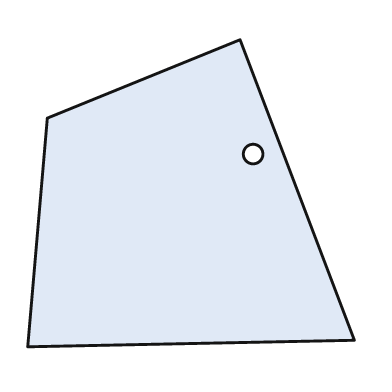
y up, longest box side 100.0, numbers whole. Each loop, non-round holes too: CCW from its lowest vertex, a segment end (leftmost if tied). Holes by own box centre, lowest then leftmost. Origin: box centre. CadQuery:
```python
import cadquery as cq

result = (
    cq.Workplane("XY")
    .moveTo(-50.0, -47.0)
    .lineTo(50.0, -45.0)
    .lineTo(15.0, 47.0)
    .lineTo(-44.0, 23.0)
    .close()
    .moveTo(19.0, 12.0)
    .circle(3.0)
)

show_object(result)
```